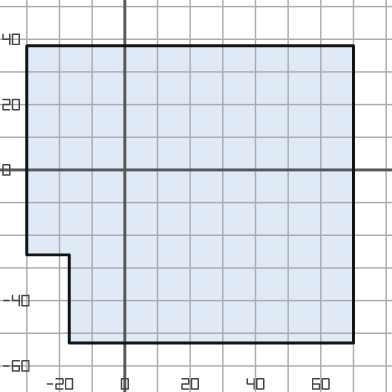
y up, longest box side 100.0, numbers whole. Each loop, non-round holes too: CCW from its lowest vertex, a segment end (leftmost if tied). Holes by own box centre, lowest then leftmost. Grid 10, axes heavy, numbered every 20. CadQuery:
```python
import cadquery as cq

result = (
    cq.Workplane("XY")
    .moveTo(-17.0, -53.0)
    .lineTo(70.0, -53.0)
    .lineTo(70.0, 38.0)
    .lineTo(-30.0, 38.0)
    .lineTo(-30.0, -26.0)
    .lineTo(-17.0, -26.0)
    .close()
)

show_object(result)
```